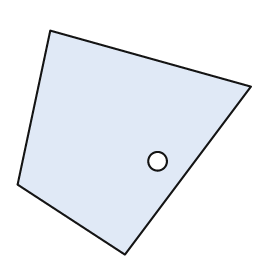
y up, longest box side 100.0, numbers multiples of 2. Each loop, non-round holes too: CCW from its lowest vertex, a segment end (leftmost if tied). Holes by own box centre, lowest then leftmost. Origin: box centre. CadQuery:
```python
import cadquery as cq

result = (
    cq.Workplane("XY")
    .moveTo(-4.0, -48.0)
    .lineTo(50.0, 24.0)
    .lineTo(-36.0, 48.0)
    .lineTo(-50.0, -18.0)
    .close()
    .moveTo(10.0, -8.0)
    .circle(4.0)
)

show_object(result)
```